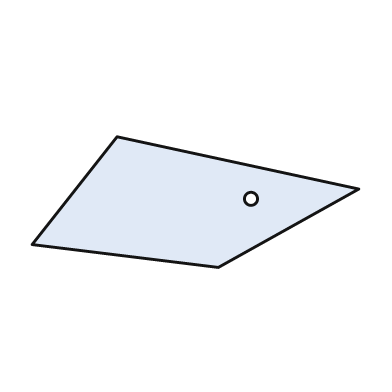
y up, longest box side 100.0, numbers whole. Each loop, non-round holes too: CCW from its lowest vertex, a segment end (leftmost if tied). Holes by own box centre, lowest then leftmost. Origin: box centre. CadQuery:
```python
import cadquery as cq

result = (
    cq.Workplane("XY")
    .moveTo(7.0, -20.0)
    .lineTo(50.0, 4.0)
    .lineTo(-24.0, 20.0)
    .lineTo(-50.0, -13.0)
    .close()
    .moveTo(17.0, 1.0)
    .circle(2.0)
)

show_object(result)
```